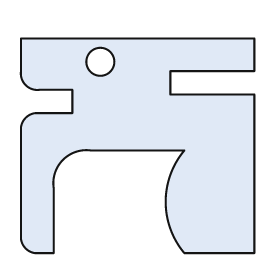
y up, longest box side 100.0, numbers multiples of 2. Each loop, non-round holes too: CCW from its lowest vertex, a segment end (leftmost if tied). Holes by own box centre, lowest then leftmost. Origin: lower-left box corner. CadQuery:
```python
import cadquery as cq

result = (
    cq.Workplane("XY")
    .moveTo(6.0, 0.0)
    .lineTo(14.0, 0.0)
    .lineTo(14.0, 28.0)
    .threePointArc((18.0, 40.0), (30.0, 44.0))
    .lineTo(70.0, 44.0)
    .threePointArc((62.0, 22.0), (70.0, 0.0))
    .lineTo(100.0, 0.0)
    .lineTo(100.0, 68.0)
    .lineTo(64.0, 68.0)
    .lineTo(64.0, 78.0)
    .lineTo(100.0, 78.0)
    .lineTo(100.0, 92.0)
    .lineTo(0.0, 92.0)
    .lineTo(0.0, 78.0)
    .threePointArc((2.0, 72.0), (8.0, 70.0))
    .lineTo(22.0, 70.0)
    .lineTo(22.0, 60.0)
    .lineTo(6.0, 60.0)
    .threePointArc((2.0, 58.0), (0.0, 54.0))
    .lineTo(0.0, 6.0)
    .threePointArc((2.0, 2.0), (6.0, 0.0))
    .close()
    .moveTo(34.0, 82.0)
    .circle(6.0)
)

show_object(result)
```